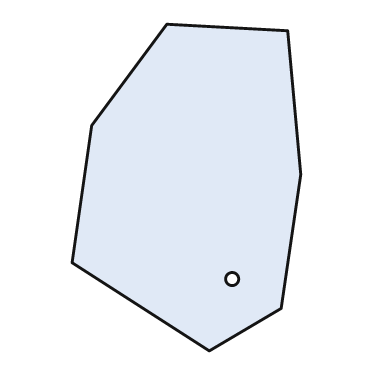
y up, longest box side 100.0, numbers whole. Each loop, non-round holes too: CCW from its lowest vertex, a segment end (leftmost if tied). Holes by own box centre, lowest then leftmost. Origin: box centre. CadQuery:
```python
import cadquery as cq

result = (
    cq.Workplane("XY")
    .moveTo(7.0, -50.0)
    .lineTo(29.0, -37.0)
    .lineTo(35.0, 4.0)
    .lineTo(31.0, 48.0)
    .lineTo(-6.0, 50.0)
    .lineTo(-29.0, 19.0)
    .lineTo(-35.0, -23.0)
    .close()
    .moveTo(14.0, -28.0)
    .circle(2.0)
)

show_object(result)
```